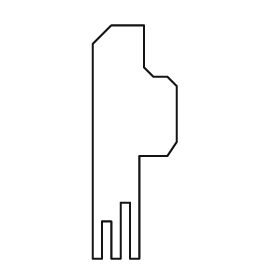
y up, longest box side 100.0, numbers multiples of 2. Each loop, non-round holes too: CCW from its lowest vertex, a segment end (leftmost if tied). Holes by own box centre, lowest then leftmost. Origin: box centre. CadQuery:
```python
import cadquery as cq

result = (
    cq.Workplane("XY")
    .moveTo(-18.0, -50.0)
    .lineTo(-14.0, -50.0)
    .lineTo(-14.0, -34.0)
    .lineTo(-10.0, -34.0)
    .lineTo(-10.0, -50.0)
    .lineTo(-6.0, -50.0)
    .lineTo(-6.0, -26.0)
    .lineTo(-2.0, -26.0)
    .lineTo(-2.0, -50.0)
    .lineTo(2.0, -50.0)
    .lineTo(2.0, -6.0)
    .lineTo(14.0, -6.0)
    .lineTo(18.0, 0.0)
    .lineTo(18.0, 24.0)
    .lineTo(14.0, 28.0)
    .lineTo(8.0, 28.0)
    .lineTo(4.0, 32.0)
    .lineTo(4.0, 50.0)
    .lineTo(-10.0, 50.0)
    .lineTo(-18.0, 42.0)
    .close()
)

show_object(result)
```